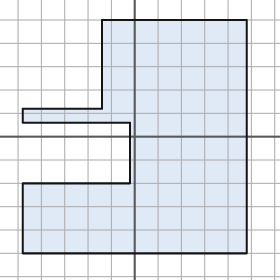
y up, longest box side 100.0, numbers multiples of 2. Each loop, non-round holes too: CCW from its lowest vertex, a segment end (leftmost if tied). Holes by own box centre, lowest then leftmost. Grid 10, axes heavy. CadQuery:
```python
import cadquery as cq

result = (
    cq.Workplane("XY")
    .moveTo(-48.0, -50.0)
    .lineTo(48.0, -50.0)
    .lineTo(48.0, 50.0)
    .lineTo(-14.0, 50.0)
    .lineTo(-14.0, 12.0)
    .lineTo(-48.0, 12.0)
    .lineTo(-48.0, 6.0)
    .lineTo(-2.0, 6.0)
    .lineTo(-2.0, -20.0)
    .lineTo(-48.0, -20.0)
    .close()
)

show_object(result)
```